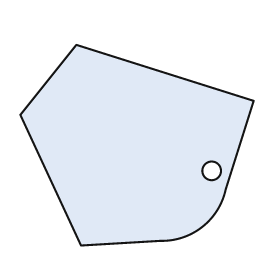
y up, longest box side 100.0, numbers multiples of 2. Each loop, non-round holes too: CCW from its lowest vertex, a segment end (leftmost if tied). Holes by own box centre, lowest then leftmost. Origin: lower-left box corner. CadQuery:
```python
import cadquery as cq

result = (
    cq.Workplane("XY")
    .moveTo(26.0, 0.0)
    .lineTo(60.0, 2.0)
    .threePointArc((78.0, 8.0), (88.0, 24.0))
    .lineTo(100.0, 62.0)
    .lineTo(24.0, 86.0)
    .lineTo(0.0, 56.0)
    .close()
    .moveTo(82.0, 32.0)
    .circle(4.0)
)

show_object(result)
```